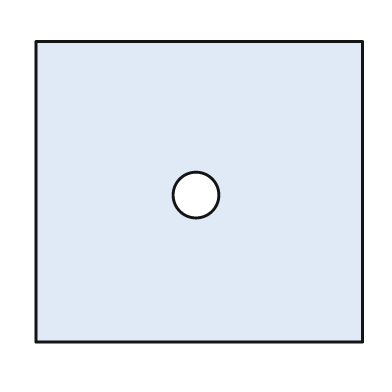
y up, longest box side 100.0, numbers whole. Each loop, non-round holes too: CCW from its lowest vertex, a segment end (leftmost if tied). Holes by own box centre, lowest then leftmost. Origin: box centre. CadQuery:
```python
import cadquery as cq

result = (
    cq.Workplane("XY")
    .moveTo(-50.0, -46.0)
    .lineTo(50.0, -46.0)
    .lineTo(50.0, 46.0)
    .lineTo(-50.0, 46.0)
    .close()
    .moveTo(-1.0, -1.0)
    .circle(7.0)
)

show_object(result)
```